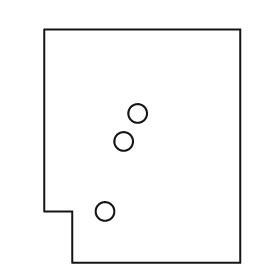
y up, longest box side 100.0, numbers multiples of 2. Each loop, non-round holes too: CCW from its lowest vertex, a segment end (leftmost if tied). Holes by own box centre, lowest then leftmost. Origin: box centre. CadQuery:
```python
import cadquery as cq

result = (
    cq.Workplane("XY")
    .moveTo(-30.0, -50.0)
    .lineTo(42.0, -50.0)
    .lineTo(42.0, 50.0)
    .lineTo(-42.0, 50.0)
    .lineTo(-42.0, -28.0)
    .lineTo(-30.0, -28.0)
    .close()
    .moveTo(-16.0, -28.0)
    .circle(4.0)
    .moveTo(-8.0, 2.0)
    .circle(4.0)
    .moveTo(-2.0, 14.0)
    .circle(4.0)
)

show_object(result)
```